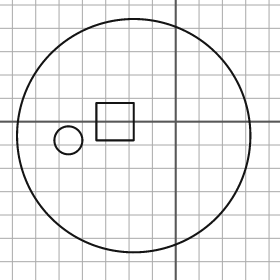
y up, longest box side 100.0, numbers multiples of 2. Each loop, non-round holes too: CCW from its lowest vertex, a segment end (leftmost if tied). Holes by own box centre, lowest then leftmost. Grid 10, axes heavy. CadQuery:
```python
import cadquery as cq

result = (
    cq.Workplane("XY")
    .moveTo(-18.0, -6.0)
    .circle(50.0)
    .moveTo(-46.0, -8.0)
    .circle(6.0)
    .moveTo(-34.0, -8.0)
    .lineTo(-18.0, -8.0)
    .lineTo(-18.0, 8.0)
    .lineTo(-34.0, 8.0)
    .close()
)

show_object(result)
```